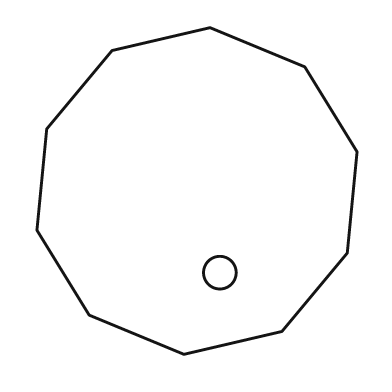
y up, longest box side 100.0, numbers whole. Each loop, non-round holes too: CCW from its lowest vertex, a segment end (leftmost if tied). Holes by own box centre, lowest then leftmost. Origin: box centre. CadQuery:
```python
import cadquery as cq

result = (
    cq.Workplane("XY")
    .moveTo(-4.0, -50.0)
    .lineTo(26.0, -43.0)
    .lineTo(46.0, -19.0)
    .lineTo(49.0, 12.0)
    .lineTo(33.0, 38.0)
    .lineTo(4.0, 50.0)
    .lineTo(-26.0, 43.0)
    .lineTo(-46.0, 19.0)
    .lineTo(-49.0, -12.0)
    .lineTo(-33.0, -38.0)
    .close()
    .moveTo(7.0, -25.0)
    .circle(5.0)
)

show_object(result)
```